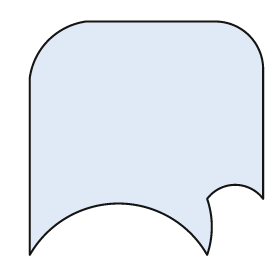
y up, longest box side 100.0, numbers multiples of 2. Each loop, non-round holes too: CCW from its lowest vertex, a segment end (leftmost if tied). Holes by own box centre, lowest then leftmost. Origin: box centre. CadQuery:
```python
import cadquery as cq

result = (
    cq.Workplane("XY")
    .moveTo(-50.0, -50.0)
    .threePointArc((-12.0, -28.0), (26.0, -50.0))
    .threePointArc((28.0, -38.0), (26.0, -26.0))
    .threePointArc((38.0, -20.0), (50.0, -26.0))
    .lineTo(50.0, 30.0)
    .threePointArc((44.0, 44.0), (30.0, 50.0))
    .lineTo(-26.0, 50.0)
    .threePointArc((-42.0, 42.0), (-50.0, 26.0))
    .close()
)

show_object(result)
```